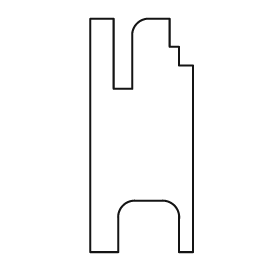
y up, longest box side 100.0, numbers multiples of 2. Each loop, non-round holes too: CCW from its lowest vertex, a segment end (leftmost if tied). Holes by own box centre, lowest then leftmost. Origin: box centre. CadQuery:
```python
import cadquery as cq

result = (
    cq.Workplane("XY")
    .moveTo(-22.0, -50.0)
    .lineTo(-10.0, -50.0)
    .lineTo(-10.0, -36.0)
    .threePointArc((-8.0, -30.0), (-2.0, -28.0))
    .lineTo(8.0, -28.0)
    .threePointArc((14.0, -30.0), (16.0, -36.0))
    .lineTo(16.0, -50.0)
    .lineTo(22.0, -50.0)
    .lineTo(22.0, 30.0)
    .lineTo(16.0, 30.0)
    .lineTo(16.0, 38.0)
    .lineTo(12.0, 38.0)
    .lineTo(12.0, 50.0)
    .lineTo(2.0, 50.0)
    .threePointArc((-2.0, 48.0), (-4.0, 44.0))
    .lineTo(-4.0, 20.0)
    .lineTo(-12.0, 20.0)
    .lineTo(-12.0, 50.0)
    .lineTo(-22.0, 50.0)
    .close()
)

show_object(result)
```